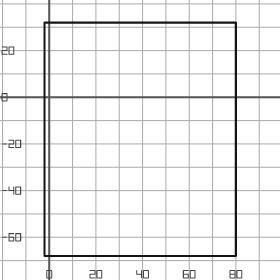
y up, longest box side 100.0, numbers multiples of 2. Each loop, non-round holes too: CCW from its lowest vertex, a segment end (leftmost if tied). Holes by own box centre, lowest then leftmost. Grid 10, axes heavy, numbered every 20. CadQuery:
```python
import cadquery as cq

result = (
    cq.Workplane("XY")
    .moveTo(-2.0, -68.0)
    .lineTo(80.0, -68.0)
    .lineTo(80.0, 32.0)
    .lineTo(-2.0, 32.0)
    .close()
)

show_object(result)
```